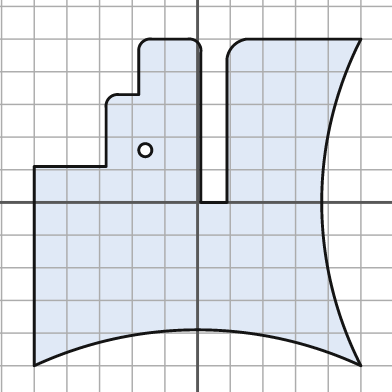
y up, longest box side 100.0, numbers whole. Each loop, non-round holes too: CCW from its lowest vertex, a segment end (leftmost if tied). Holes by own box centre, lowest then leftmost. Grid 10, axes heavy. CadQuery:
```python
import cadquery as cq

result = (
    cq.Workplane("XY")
    .moveTo(-50.0, -50.0)
    .threePointArc((0.0, -39.0), (50.0, -50.0))
    .threePointArc((38.0, 0.0), (50.0, 50.0))
    .lineTo(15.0, 50.0)
    .threePointArc((11.0, 48.0), (9.0, 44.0))
    .lineTo(9.0, 0.0)
    .lineTo(1.0, 0.0)
    .lineTo(1.0, 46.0)
    .threePointArc((0.0, 49.0), (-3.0, 50.0))
    .lineTo(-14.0, 50.0)
    .threePointArc((-17.0, 49.0), (-18.0, 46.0))
    .lineTo(-18.0, 33.0)
    .lineTo(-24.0, 33.0)
    .threePointArc((-27.0, 32.0), (-28.0, 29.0))
    .lineTo(-28.0, 11.0)
    .lineTo(-50.0, 11.0)
    .close()
    .moveTo(-16.0, 16.0)
    .circle(2.0)
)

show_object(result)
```